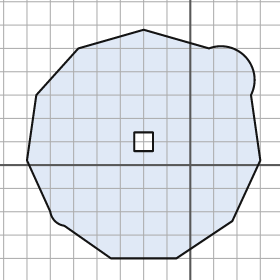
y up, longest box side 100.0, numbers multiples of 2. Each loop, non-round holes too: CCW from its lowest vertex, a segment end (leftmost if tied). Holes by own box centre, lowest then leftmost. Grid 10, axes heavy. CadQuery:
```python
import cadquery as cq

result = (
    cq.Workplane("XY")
    .moveTo(-34.0, -40.0)
    .lineTo(-6.0, -40.0)
    .lineTo(18.0, -24.0)
    .lineTo(30.0, 2.0)
    .lineTo(26.0, 30.0)
    .threePointArc((24.0, 46.0), (8.0, 50.0))
    .lineTo(-20.0, 58.0)
    .lineTo(-48.0, 50.0)
    .lineTo(-66.0, 30.0)
    .lineTo(-70.0, 2.0)
    .lineTo(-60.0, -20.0)
    .threePointArc((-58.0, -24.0), (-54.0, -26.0))
    .close()
    .moveTo(-24.0, 6.0)
    .lineTo(-16.0, 6.0)
    .lineTo(-16.0, 14.0)
    .lineTo(-24.0, 14.0)
    .close()
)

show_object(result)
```